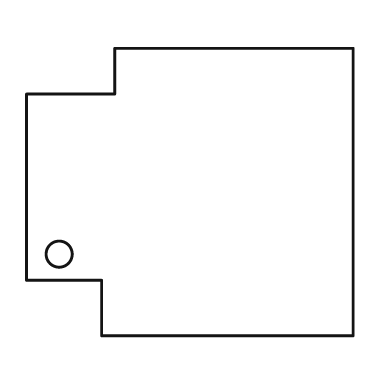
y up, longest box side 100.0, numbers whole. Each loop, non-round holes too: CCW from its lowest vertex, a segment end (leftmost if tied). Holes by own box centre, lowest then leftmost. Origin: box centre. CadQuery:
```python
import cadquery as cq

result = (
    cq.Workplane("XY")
    .moveTo(-27.0, -44.0)
    .lineTo(50.0, -44.0)
    .lineTo(50.0, 44.0)
    .lineTo(-23.0, 44.0)
    .lineTo(-23.0, 30.0)
    .lineTo(-50.0, 30.0)
    .lineTo(-50.0, -27.0)
    .lineTo(-27.0, -27.0)
    .close()
    .moveTo(-40.0, -19.0)
    .circle(4.0)
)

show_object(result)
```